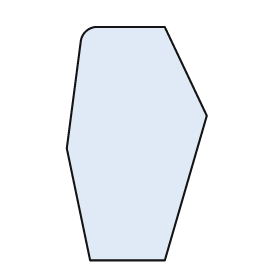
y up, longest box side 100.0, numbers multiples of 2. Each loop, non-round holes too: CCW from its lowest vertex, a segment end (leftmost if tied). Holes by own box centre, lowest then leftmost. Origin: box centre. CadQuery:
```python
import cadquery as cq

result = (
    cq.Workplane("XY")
    .moveTo(-20.0, -50.0)
    .lineTo(12.0, -50.0)
    .lineTo(30.0, 12.0)
    .lineTo(12.0, 50.0)
    .lineTo(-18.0, 50.0)
    .threePointArc((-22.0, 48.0), (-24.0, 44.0))
    .lineTo(-30.0, -2.0)
    .close()
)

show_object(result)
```